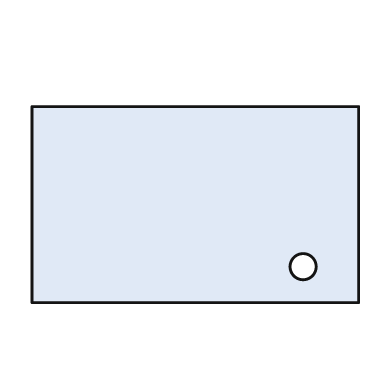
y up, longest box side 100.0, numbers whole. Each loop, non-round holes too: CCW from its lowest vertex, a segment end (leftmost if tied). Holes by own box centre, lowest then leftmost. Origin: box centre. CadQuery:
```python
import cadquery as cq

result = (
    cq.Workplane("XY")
    .moveTo(-50.0, -30.0)
    .lineTo(50.0, -30.0)
    .lineTo(50.0, 30.0)
    .lineTo(-50.0, 30.0)
    .close()
    .moveTo(33.0, -19.0)
    .circle(4.0)
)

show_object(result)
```